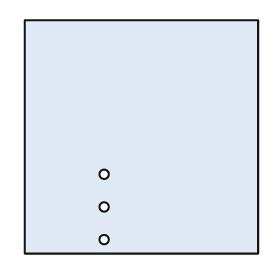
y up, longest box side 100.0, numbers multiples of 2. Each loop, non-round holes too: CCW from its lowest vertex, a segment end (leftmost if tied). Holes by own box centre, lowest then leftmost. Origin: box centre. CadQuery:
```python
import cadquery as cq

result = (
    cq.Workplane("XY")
    .moveTo(-50.0, -50.0)
    .lineTo(50.0, -50.0)
    .lineTo(50.0, 50.0)
    .lineTo(-50.0, 50.0)
    .close()
    .moveTo(-16.0, -44.0)
    .circle(2.0)
    .moveTo(-16.0, -30.0)
    .circle(2.0)
    .moveTo(-16.0, -16.0)
    .circle(2.0)
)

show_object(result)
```